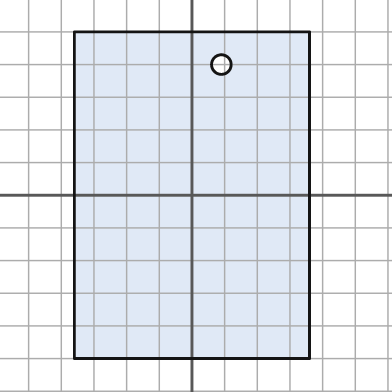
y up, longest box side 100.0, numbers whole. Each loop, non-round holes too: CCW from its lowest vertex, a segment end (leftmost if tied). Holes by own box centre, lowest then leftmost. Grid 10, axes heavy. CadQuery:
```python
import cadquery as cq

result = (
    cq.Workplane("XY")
    .moveTo(-36.0, -50.0)
    .lineTo(36.0, -50.0)
    .lineTo(36.0, 50.0)
    .lineTo(-36.0, 50.0)
    .close()
    .moveTo(9.0, 40.0)
    .circle(3.0)
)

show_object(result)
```